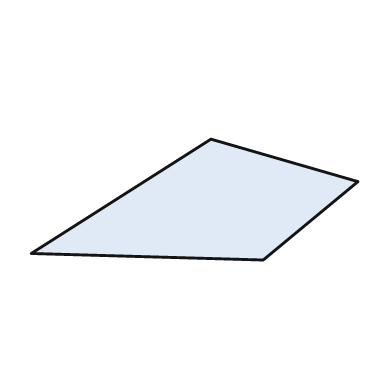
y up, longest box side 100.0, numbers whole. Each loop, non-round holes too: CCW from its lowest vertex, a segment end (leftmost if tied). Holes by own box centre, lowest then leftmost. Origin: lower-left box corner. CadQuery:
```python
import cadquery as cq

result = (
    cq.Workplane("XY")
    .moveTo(71.0, 0.0)
    .lineTo(100.0, 24.0)
    .lineTo(55.0, 37.0)
    .lineTo(0.0, 2.0)
    .close()
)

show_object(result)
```